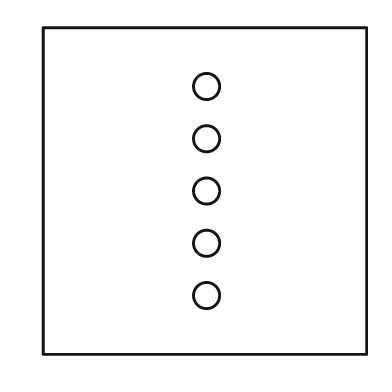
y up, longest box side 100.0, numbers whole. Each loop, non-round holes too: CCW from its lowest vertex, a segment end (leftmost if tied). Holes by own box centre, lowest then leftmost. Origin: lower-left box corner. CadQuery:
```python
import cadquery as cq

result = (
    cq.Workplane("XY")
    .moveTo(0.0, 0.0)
    .lineTo(99.0, 0.0)
    .lineTo(99.0, 100.0)
    .lineTo(0.0, 100.0)
    .close()
    .moveTo(50.0, 18.0)
    .circle(4.0)
    .moveTo(50.0, 34.0)
    .circle(4.0)
    .moveTo(50.0, 50.0)
    .circle(4.0)
    .moveTo(50.0, 66.0)
    .circle(4.0)
    .moveTo(50.0, 82.0)
    .circle(4.0)
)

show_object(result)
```